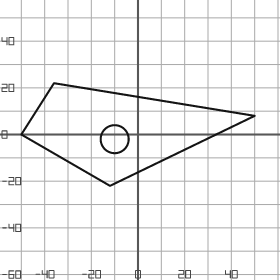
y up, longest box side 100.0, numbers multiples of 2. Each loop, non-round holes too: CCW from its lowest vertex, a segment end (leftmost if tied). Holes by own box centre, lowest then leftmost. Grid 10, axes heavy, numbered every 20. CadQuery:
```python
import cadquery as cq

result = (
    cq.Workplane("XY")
    .moveTo(-12.0, -22.0)
    .lineTo(50.0, 8.0)
    .lineTo(-36.0, 22.0)
    .lineTo(-50.0, 0.0)
    .close()
    .moveTo(-10.0, -2.0)
    .circle(6.0)
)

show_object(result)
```